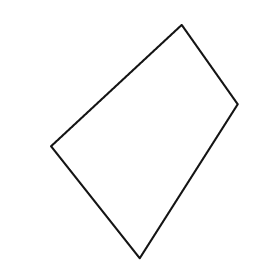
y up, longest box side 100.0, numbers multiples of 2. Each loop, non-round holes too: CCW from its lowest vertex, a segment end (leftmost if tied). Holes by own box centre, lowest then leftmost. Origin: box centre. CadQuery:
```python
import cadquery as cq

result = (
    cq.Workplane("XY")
    .moveTo(-2.0, -50.0)
    .lineTo(40.0, 16.0)
    .lineTo(16.0, 50.0)
    .lineTo(-40.0, -2.0)
    .close()
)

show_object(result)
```